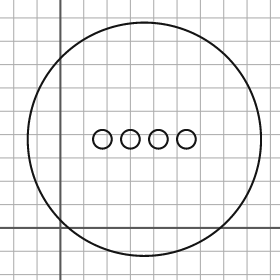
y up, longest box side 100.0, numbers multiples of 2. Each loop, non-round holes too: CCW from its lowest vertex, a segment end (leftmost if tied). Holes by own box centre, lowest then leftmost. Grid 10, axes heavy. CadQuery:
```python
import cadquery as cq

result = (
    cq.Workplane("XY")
    .moveTo(36.0, 38.0)
    .circle(50.0)
    .moveTo(18.0, 38.0)
    .circle(4.0)
    .moveTo(30.0, 38.0)
    .circle(4.0)
    .moveTo(42.0, 38.0)
    .circle(4.0)
    .moveTo(54.0, 38.0)
    .circle(4.0)
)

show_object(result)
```